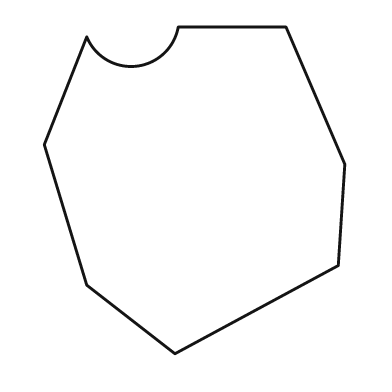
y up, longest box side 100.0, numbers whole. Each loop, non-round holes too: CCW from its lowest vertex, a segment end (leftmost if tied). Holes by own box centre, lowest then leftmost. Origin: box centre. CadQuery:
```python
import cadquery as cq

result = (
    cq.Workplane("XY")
    .moveTo(-6.0, -50.0)
    .lineTo(44.0, -23.0)
    .lineTo(46.0, 8.0)
    .lineTo(28.0, 50.0)
    .lineTo(-5.0, 50.0)
    .threePointArc((-18.0, 38.0), (-33.0, 47.0))
    .lineTo(-46.0, 14.0)
    .lineTo(-33.0, -29.0)
    .close()
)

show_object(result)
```